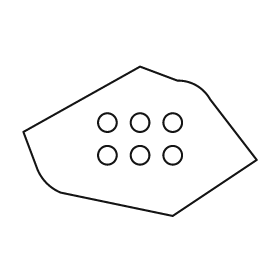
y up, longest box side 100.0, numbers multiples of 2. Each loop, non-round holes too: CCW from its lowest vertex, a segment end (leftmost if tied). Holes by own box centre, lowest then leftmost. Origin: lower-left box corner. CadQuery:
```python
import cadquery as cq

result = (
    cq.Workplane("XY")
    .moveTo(64.0, 0.0)
    .lineTo(100.0, 24.0)
    .lineTo(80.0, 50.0)
    .threePointArc((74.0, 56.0), (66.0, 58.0))
    .lineTo(50.0, 64.0)
    .lineTo(0.0, 36.0)
    .lineTo(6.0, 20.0)
    .threePointArc((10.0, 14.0), (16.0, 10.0))
    .close()
    .moveTo(36.0, 26.0)
    .circle(4.0)
    .moveTo(50.0, 26.0)
    .circle(4.0)
    .moveTo(64.0, 26.0)
    .circle(4.0)
    .moveTo(36.0, 40.0)
    .circle(4.0)
    .moveTo(50.0, 40.0)
    .circle(4.0)
    .moveTo(64.0, 40.0)
    .circle(4.0)
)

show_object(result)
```